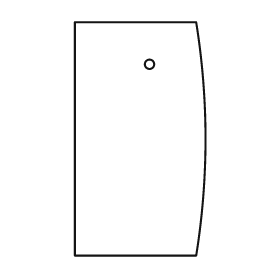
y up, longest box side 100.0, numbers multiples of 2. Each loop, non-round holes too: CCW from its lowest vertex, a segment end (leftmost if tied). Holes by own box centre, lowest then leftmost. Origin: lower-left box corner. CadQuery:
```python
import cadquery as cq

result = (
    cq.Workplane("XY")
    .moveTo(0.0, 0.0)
    .lineTo(52.0, 0.0)
    .threePointArc((56.0, 50.0), (52.0, 100.0))
    .lineTo(0.0, 100.0)
    .close()
    .moveTo(32.0, 82.0)
    .circle(2.0)
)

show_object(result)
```